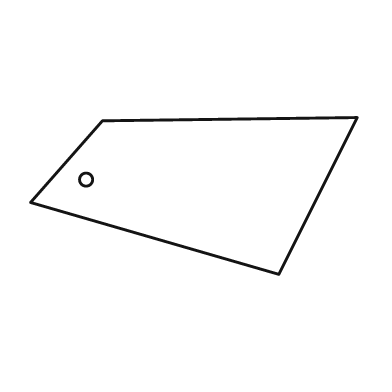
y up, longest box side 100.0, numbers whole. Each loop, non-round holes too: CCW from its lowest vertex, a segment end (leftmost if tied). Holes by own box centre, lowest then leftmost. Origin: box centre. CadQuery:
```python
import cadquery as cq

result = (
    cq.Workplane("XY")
    .moveTo(26.0, -24.0)
    .lineTo(50.0, 24.0)
    .lineTo(-28.0, 23.0)
    .lineTo(-50.0, -2.0)
    .close()
    .moveTo(-33.0, 5.0)
    .circle(2.0)
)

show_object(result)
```